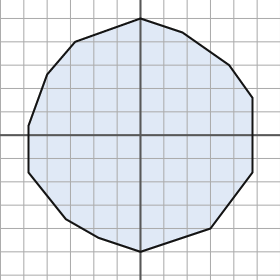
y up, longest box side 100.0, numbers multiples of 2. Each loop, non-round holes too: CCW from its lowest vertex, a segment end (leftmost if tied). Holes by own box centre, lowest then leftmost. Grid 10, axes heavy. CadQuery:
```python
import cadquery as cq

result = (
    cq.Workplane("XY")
    .moveTo(0.0, -50.0)
    .lineTo(30.0, -40.0)
    .lineTo(48.0, -16.0)
    .lineTo(48.0, 16.0)
    .lineTo(38.0, 30.0)
    .lineTo(18.0, 44.0)
    .lineTo(0.0, 50.0)
    .lineTo(-28.0, 40.0)
    .lineTo(-40.0, 26.0)
    .lineTo(-48.0, 4.0)
    .lineTo(-48.0, -16.0)
    .lineTo(-32.0, -36.0)
    .lineTo(-18.0, -44.0)
    .close()
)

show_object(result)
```